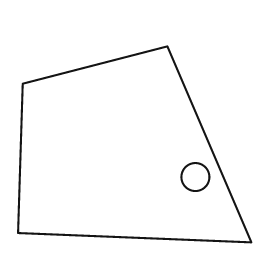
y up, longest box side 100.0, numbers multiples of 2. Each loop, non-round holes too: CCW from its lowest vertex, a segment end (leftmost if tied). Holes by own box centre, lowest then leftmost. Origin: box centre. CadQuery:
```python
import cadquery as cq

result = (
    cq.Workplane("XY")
    .moveTo(50.0, -42.0)
    .lineTo(14.0, 42.0)
    .lineTo(-48.0, 26.0)
    .lineTo(-50.0, -38.0)
    .close()
    .moveTo(26.0, -14.0)
    .circle(6.0)
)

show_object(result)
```